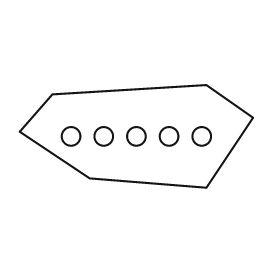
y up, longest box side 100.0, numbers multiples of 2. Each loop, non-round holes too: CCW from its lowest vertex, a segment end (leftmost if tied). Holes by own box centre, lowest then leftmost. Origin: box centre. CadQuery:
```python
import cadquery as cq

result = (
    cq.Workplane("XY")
    .moveTo(30.0, -22.0)
    .lineTo(50.0, 8.0)
    .lineTo(30.0, 22.0)
    .lineTo(-36.0, 18.0)
    .lineTo(-50.0, 2.0)
    .lineTo(-20.0, -18.0)
    .close()
    .moveTo(-28.0, 0.0)
    .circle(4.0)
    .moveTo(-14.0, 0.0)
    .circle(4.0)
    .moveTo(0.0, 0.0)
    .circle(4.0)
    .moveTo(14.0, 0.0)
    .circle(4.0)
    .moveTo(28.0, 0.0)
    .circle(4.0)
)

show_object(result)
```